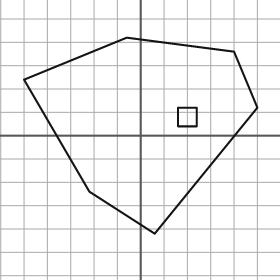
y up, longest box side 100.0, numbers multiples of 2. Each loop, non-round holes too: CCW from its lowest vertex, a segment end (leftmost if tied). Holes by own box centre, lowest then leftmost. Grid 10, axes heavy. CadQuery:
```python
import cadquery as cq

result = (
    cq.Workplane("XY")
    .moveTo(6.0, -42.0)
    .lineTo(50.0, 12.0)
    .lineTo(40.0, 36.0)
    .lineTo(-6.0, 42.0)
    .lineTo(-50.0, 24.0)
    .lineTo(-22.0, -24.0)
    .close()
    .moveTo(16.0, 4.0)
    .lineTo(24.0, 4.0)
    .lineTo(24.0, 12.0)
    .lineTo(16.0, 12.0)
    .close()
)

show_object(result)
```